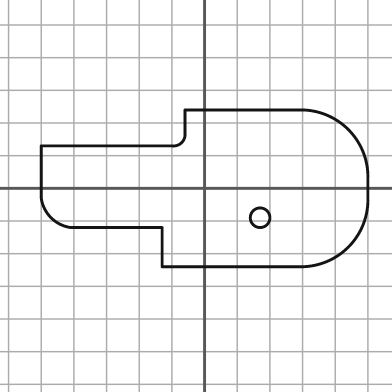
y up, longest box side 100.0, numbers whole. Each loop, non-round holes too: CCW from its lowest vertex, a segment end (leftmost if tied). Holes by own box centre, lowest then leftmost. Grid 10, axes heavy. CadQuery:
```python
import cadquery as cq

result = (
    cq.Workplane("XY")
    .moveTo(-13.0, -24.0)
    .lineTo(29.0, -24.0)
    .threePointArc((44.0, -18.0), (50.0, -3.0))
    .lineTo(50.0, 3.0)
    .threePointArc((44.0, 18.0), (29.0, 24.0))
    .lineTo(-6.0, 24.0)
    .lineTo(-6.0, 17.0)
    .threePointArc((-7.0, 14.0), (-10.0, 13.0))
    .lineTo(-50.0, 13.0)
    .lineTo(-50.0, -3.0)
    .threePointArc((-47.0, -9.0), (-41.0, -12.0))
    .lineTo(-13.0, -12.0)
    .close()
    .moveTo(17.0, -9.0)
    .circle(3.0)
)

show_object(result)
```